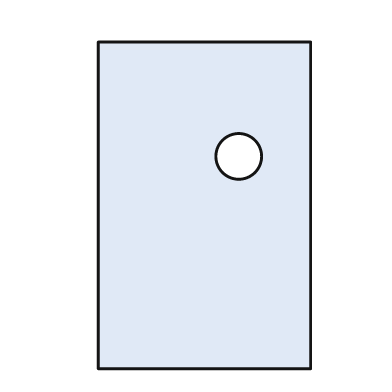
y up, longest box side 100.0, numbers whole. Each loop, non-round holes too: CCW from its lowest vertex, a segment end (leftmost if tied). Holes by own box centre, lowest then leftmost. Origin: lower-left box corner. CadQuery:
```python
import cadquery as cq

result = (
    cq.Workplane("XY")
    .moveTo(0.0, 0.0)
    .lineTo(65.0, 0.0)
    .lineTo(65.0, 100.0)
    .lineTo(0.0, 100.0)
    .close()
    .moveTo(43.0, 65.0)
    .circle(7.0)
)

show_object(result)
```